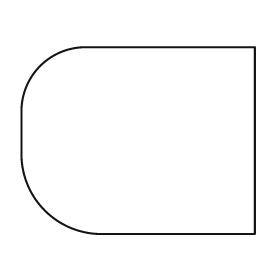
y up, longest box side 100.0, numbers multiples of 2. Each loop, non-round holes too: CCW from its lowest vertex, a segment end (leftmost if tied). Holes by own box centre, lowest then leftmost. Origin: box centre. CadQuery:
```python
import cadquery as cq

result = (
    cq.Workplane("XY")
    .moveTo(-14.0, -40.0)
    .lineTo(50.0, -40.0)
    .lineTo(50.0, 40.0)
    .lineTo(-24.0, 40.0)
    .threePointArc((-42.0, 32.0), (-50.0, 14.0))
    .lineTo(-50.0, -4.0)
    .threePointArc((-40.0, -30.0), (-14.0, -40.0))
    .close()
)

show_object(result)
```